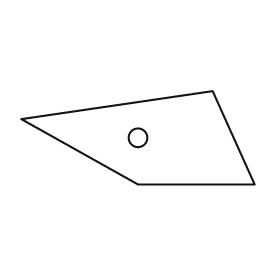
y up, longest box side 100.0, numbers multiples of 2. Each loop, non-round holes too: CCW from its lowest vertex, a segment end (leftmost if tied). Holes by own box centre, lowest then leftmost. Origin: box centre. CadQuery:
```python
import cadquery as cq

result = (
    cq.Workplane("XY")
    .moveTo(0.0, -20.0)
    .lineTo(50.0, -20.0)
    .lineTo(32.0, 20.0)
    .lineTo(-50.0, 8.0)
    .close()
    .moveTo(0.0, 0.0)
    .circle(4.0)
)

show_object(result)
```